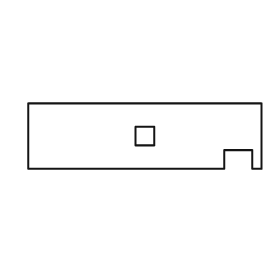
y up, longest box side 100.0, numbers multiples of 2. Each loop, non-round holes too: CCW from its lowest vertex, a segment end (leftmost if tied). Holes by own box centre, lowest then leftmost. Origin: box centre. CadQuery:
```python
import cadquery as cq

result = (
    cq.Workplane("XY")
    .moveTo(-50.0, -14.0)
    .lineTo(34.0, -14.0)
    .lineTo(34.0, -6.0)
    .lineTo(46.0, -6.0)
    .lineTo(46.0, -14.0)
    .lineTo(50.0, -14.0)
    .lineTo(50.0, 14.0)
    .lineTo(-50.0, 14.0)
    .close()
    .moveTo(-4.0, -4.0)
    .lineTo(4.0, -4.0)
    .lineTo(4.0, 4.0)
    .lineTo(-4.0, 4.0)
    .close()
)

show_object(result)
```